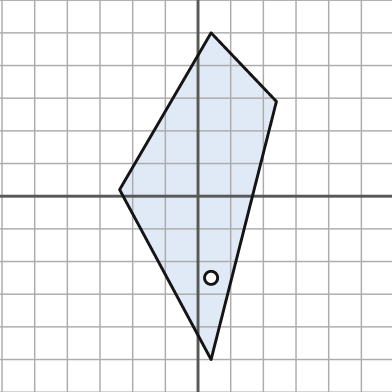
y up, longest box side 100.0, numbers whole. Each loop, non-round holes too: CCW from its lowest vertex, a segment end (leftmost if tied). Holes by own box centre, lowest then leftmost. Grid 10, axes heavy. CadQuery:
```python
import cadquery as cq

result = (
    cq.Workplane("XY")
    .moveTo(4.0, -50.0)
    .lineTo(24.0, 29.0)
    .lineTo(4.0, 50.0)
    .lineTo(-24.0, 2.0)
    .close()
    .moveTo(4.0, -25.0)
    .circle(2.0)
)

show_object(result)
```